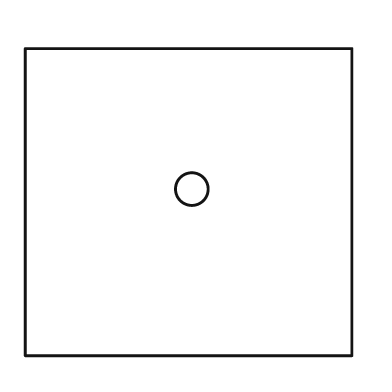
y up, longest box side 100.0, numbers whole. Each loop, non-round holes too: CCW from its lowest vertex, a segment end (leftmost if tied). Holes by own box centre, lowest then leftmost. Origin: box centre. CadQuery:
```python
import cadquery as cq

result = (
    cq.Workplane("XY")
    .moveTo(-50.0, -47.0)
    .lineTo(50.0, -47.0)
    .lineTo(50.0, 47.0)
    .lineTo(-50.0, 47.0)
    .close()
    .moveTo(1.0, 4.0)
    .circle(5.0)
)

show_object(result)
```